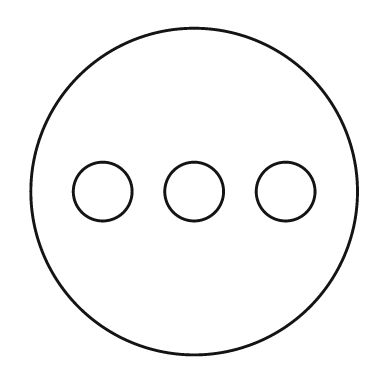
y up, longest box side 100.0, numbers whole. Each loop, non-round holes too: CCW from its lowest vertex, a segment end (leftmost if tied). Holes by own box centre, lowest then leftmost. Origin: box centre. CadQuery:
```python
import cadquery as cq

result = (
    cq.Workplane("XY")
    .moveTo(0.0, 0.0)
    .circle(50.0)
    .moveTo(-28.0, 0.0)
    .circle(9.0)
    .moveTo(0.0, 0.0)
    .circle(9.0)
    .moveTo(28.0, 0.0)
    .circle(9.0)
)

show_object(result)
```